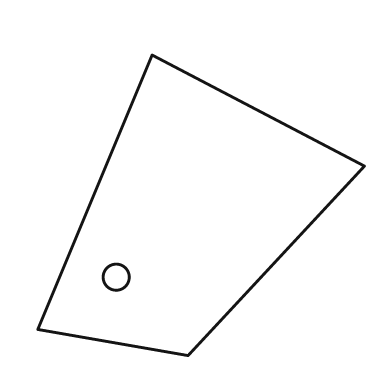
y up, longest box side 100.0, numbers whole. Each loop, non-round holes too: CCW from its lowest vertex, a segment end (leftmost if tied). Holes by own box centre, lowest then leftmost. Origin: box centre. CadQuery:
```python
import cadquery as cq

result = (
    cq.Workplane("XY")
    .moveTo(-4.0, -46.0)
    .lineTo(50.0, 12.0)
    .lineTo(-15.0, 46.0)
    .lineTo(-50.0, -38.0)
    .close()
    .moveTo(-26.0, -22.0)
    .circle(4.0)
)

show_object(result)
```